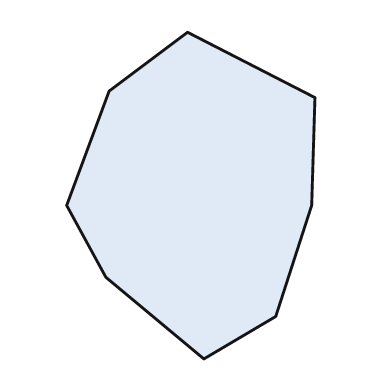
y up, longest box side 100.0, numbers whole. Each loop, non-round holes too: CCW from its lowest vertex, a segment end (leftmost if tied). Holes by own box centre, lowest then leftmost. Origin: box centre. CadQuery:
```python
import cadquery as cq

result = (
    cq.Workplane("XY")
    .moveTo(4.0, -50.0)
    .lineTo(26.0, -37.0)
    .lineTo(37.0, -3.0)
    .lineTo(38.0, 30.0)
    .lineTo(-1.0, 50.0)
    .lineTo(-25.0, 32.0)
    .lineTo(-38.0, -3.0)
    .lineTo(-26.0, -25.0)
    .close()
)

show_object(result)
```